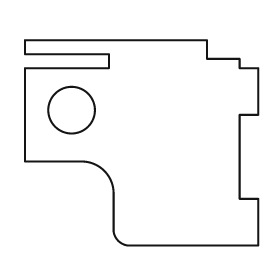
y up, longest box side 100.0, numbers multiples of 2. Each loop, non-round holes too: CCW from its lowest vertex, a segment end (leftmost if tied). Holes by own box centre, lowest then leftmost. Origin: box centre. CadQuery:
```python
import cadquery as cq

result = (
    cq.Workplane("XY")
    .moveTo(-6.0, -44.0)
    .lineTo(50.0, -44.0)
    .lineTo(50.0, -24.0)
    .lineTo(42.0, -24.0)
    .lineTo(42.0, 12.0)
    .lineTo(50.0, 12.0)
    .lineTo(50.0, 32.0)
    .lineTo(42.0, 32.0)
    .lineTo(42.0, 36.0)
    .lineTo(28.0, 36.0)
    .lineTo(28.0, 44.0)
    .lineTo(-50.0, 44.0)
    .lineTo(-50.0, 38.0)
    .lineTo(-14.0, 38.0)
    .lineTo(-14.0, 32.0)
    .lineTo(-50.0, 32.0)
    .lineTo(-50.0, -8.0)
    .lineTo(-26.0, -8.0)
    .threePointArc((-16.0, -12.0), (-12.0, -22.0))
    .lineTo(-12.0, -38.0)
    .threePointArc((-10.0, -42.0), (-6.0, -44.0))
    .close()
    .moveTo(-30.0, 14.0)
    .circle(10.0)
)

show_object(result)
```